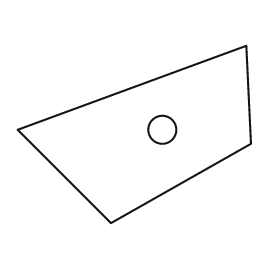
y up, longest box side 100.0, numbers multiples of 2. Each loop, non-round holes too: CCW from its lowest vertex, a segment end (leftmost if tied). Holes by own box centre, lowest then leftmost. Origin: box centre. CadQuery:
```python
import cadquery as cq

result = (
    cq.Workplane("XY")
    .moveTo(-10.0, -38.0)
    .lineTo(50.0, -4.0)
    .lineTo(48.0, 38.0)
    .lineTo(-50.0, 2.0)
    .close()
    .moveTo(12.0, 2.0)
    .circle(6.0)
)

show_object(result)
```